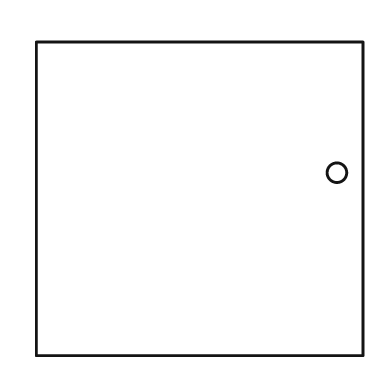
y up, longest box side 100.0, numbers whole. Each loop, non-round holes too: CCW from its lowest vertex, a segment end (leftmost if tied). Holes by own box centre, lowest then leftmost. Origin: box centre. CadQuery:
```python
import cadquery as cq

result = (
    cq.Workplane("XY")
    .moveTo(-50.0, -48.0)
    .lineTo(50.0, -48.0)
    .lineTo(50.0, 48.0)
    .lineTo(-50.0, 48.0)
    .close()
    .moveTo(42.0, 8.0)
    .circle(3.0)
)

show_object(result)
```